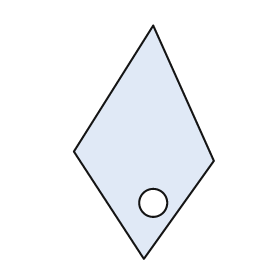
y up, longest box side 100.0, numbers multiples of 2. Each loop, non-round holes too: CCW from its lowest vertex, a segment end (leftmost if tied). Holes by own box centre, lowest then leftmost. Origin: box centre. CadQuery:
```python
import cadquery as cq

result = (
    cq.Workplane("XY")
    .moveTo(0.0, -50.0)
    .lineTo(30.0, -8.0)
    .lineTo(4.0, 50.0)
    .lineTo(-30.0, -4.0)
    .close()
    .moveTo(4.0, -26.0)
    .circle(6.0)
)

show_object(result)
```